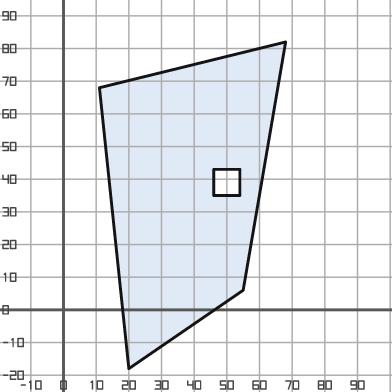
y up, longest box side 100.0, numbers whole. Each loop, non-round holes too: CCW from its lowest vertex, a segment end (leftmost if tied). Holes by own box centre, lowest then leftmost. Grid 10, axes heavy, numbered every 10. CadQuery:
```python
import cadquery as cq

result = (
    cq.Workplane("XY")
    .moveTo(20.0, -18.0)
    .lineTo(55.0, 6.0)
    .lineTo(68.0, 82.0)
    .lineTo(11.0, 68.0)
    .close()
    .moveTo(46.0, 35.0)
    .lineTo(54.0, 35.0)
    .lineTo(54.0, 43.0)
    .lineTo(46.0, 43.0)
    .close()
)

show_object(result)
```